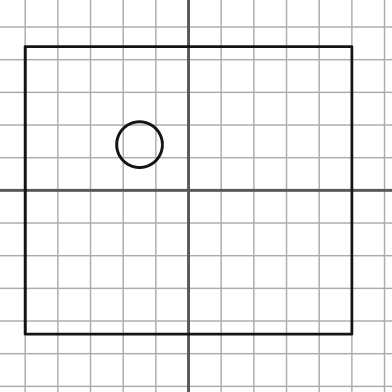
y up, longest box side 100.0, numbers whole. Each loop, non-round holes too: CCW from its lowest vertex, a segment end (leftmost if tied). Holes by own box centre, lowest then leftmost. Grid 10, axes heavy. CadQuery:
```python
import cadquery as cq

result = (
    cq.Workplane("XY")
    .moveTo(-50.0, -44.0)
    .lineTo(50.0, -44.0)
    .lineTo(50.0, 44.0)
    .lineTo(-50.0, 44.0)
    .close()
    .moveTo(-15.0, 14.0)
    .circle(7.0)
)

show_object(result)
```